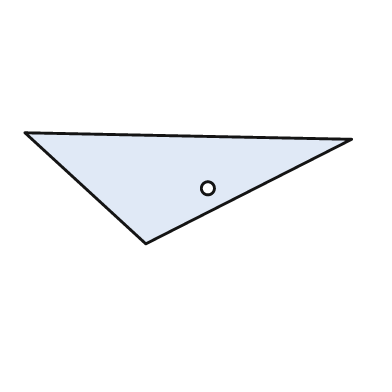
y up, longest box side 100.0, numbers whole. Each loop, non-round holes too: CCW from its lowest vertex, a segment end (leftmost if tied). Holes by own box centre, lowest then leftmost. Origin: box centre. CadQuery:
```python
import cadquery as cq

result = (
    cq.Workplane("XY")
    .moveTo(-13.0, -17.0)
    .lineTo(50.0, 15.0)
    .lineTo(-50.0, 17.0)
    .close()
    .moveTo(6.0, 0.0)
    .circle(2.0)
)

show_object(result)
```